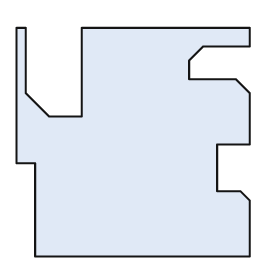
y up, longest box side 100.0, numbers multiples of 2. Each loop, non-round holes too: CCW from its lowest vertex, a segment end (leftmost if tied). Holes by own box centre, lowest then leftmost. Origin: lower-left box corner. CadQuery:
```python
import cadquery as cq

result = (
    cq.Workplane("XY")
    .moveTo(8.0, 0.0)
    .lineTo(100.0, 0.0)
    .lineTo(100.0, 24.0)
    .lineTo(96.0, 28.0)
    .lineTo(86.0, 28.0)
    .lineTo(86.0, 48.0)
    .lineTo(100.0, 48.0)
    .lineTo(100.0, 70.0)
    .lineTo(94.0, 76.0)
    .lineTo(74.0, 76.0)
    .lineTo(74.0, 84.0)
    .lineTo(80.0, 90.0)
    .lineTo(100.0, 90.0)
    .lineTo(100.0, 98.0)
    .lineTo(28.0, 98.0)
    .lineTo(28.0, 60.0)
    .lineTo(14.0, 60.0)
    .lineTo(4.0, 70.0)
    .lineTo(4.0, 98.0)
    .lineTo(0.0, 98.0)
    .lineTo(0.0, 40.0)
    .lineTo(8.0, 40.0)
    .close()
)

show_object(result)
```